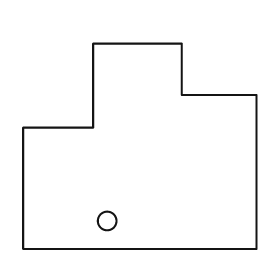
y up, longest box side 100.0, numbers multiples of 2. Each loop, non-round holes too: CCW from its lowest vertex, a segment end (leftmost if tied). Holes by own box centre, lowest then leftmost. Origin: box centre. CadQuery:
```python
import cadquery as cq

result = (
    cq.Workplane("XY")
    .moveTo(-50.0, -44.0)
    .lineTo(50.0, -44.0)
    .lineTo(50.0, 22.0)
    .lineTo(18.0, 22.0)
    .lineTo(18.0, 44.0)
    .lineTo(-20.0, 44.0)
    .lineTo(-20.0, 8.0)
    .lineTo(-50.0, 8.0)
    .close()
    .moveTo(-14.0, -32.0)
    .circle(4.0)
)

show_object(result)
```